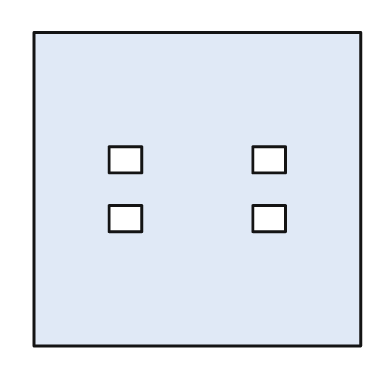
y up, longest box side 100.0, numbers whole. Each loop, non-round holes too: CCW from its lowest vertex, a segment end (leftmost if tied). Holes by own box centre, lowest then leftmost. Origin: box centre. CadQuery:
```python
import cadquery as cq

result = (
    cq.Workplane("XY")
    .moveTo(-50.0, -48.0)
    .lineTo(50.0, -48.0)
    .lineTo(50.0, 48.0)
    .lineTo(-50.0, 48.0)
    .close()
    .moveTo(-27.0, -13.0)
    .lineTo(-17.0, -13.0)
    .lineTo(-17.0, -5.0)
    .lineTo(-27.0, -5.0)
    .close()
    .moveTo(17.0, -13.0)
    .lineTo(27.0, -13.0)
    .lineTo(27.0, -5.0)
    .lineTo(17.0, -5.0)
    .close()
    .moveTo(-27.0, 5.0)
    .lineTo(-17.0, 5.0)
    .lineTo(-17.0, 13.0)
    .lineTo(-27.0, 13.0)
    .close()
    .moveTo(17.0, 5.0)
    .lineTo(27.0, 5.0)
    .lineTo(27.0, 13.0)
    .lineTo(17.0, 13.0)
    .close()
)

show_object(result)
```